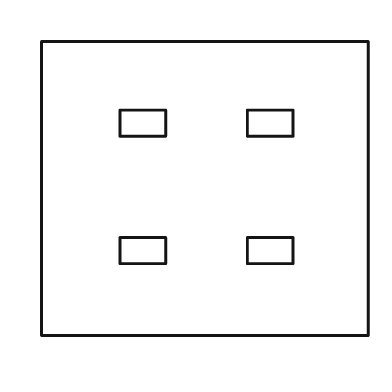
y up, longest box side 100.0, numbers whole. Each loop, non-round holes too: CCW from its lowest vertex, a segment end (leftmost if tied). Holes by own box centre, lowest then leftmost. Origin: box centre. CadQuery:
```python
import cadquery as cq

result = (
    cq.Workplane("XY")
    .moveTo(-50.0, -45.0)
    .lineTo(50.0, -45.0)
    .lineTo(50.0, 45.0)
    .lineTo(-50.0, 45.0)
    .close()
    .moveTo(-26.0, -23.0)
    .lineTo(-12.0, -23.0)
    .lineTo(-12.0, -15.0)
    .lineTo(-26.0, -15.0)
    .close()
    .moveTo(13.0, -23.0)
    .lineTo(27.0, -23.0)
    .lineTo(27.0, -15.0)
    .lineTo(13.0, -15.0)
    .close()
    .moveTo(-26.0, 16.0)
    .lineTo(-12.0, 16.0)
    .lineTo(-12.0, 24.0)
    .lineTo(-26.0, 24.0)
    .close()
    .moveTo(13.0, 16.0)
    .lineTo(27.0, 16.0)
    .lineTo(27.0, 24.0)
    .lineTo(13.0, 24.0)
    .close()
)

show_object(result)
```